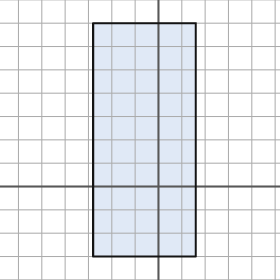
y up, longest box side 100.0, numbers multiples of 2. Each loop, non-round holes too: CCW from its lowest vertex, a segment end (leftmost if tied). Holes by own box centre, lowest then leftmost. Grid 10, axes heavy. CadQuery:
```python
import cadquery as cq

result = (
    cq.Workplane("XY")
    .moveTo(-28.0, -30.0)
    .lineTo(16.0, -30.0)
    .lineTo(16.0, 70.0)
    .lineTo(-28.0, 70.0)
    .close()
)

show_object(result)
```